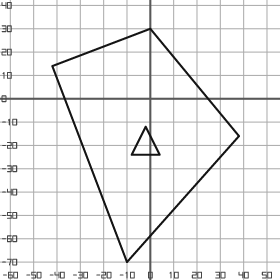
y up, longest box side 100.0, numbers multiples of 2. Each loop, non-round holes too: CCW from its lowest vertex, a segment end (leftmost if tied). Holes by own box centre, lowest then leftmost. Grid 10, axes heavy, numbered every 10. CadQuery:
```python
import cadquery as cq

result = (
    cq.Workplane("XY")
    .moveTo(-10.0, -70.0)
    .lineTo(38.0, -16.0)
    .lineTo(0.0, 30.0)
    .lineTo(-42.0, 14.0)
    .close()
    .moveTo(-8.0, -24.0)
    .lineTo(4.0, -24.0)
    .lineTo(-2.0, -12.0)
    .close()
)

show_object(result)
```